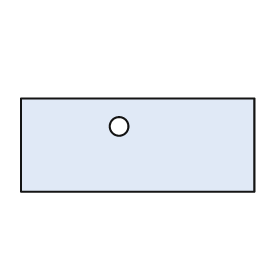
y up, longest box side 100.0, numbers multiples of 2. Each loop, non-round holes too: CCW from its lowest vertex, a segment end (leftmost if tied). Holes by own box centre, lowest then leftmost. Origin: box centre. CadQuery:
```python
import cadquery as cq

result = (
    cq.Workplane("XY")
    .moveTo(-50.0, -20.0)
    .lineTo(50.0, -20.0)
    .lineTo(50.0, 20.0)
    .lineTo(-50.0, 20.0)
    .close()
    .moveTo(-8.0, 8.0)
    .circle(4.0)
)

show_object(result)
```